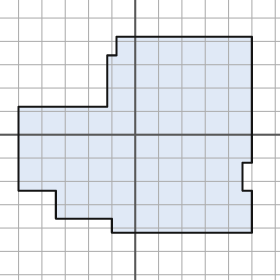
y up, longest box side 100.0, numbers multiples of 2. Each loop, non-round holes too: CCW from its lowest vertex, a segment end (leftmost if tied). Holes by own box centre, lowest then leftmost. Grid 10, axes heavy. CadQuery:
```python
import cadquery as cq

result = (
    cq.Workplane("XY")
    .moveTo(-10.0, -42.0)
    .lineTo(50.0, -42.0)
    .lineTo(50.0, -24.0)
    .lineTo(46.0, -24.0)
    .lineTo(46.0, -12.0)
    .lineTo(50.0, -12.0)
    .lineTo(50.0, 42.0)
    .lineTo(-8.0, 42.0)
    .lineTo(-8.0, 34.0)
    .lineTo(-12.0, 34.0)
    .lineTo(-12.0, 12.0)
    .lineTo(-50.0, 12.0)
    .lineTo(-50.0, -24.0)
    .lineTo(-34.0, -24.0)
    .lineTo(-34.0, -36.0)
    .lineTo(-10.0, -36.0)
    .close()
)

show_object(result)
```